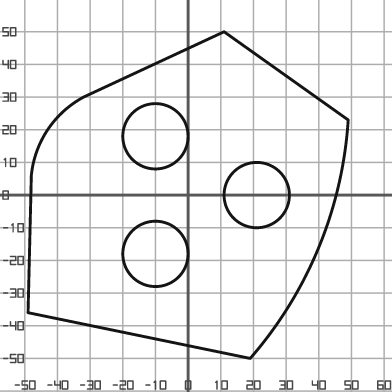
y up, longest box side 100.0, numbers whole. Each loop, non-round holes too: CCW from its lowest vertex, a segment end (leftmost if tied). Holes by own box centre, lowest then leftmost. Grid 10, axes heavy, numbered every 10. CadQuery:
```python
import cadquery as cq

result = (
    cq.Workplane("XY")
    .moveTo(19.0, -50.0)
    .threePointArc((40.0, -16.0), (49.0, 23.0))
    .lineTo(11.0, 50.0)
    .lineTo(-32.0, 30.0)
    .threePointArc((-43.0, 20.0), (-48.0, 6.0))
    .lineTo(-49.0, -36.0)
    .close()
    .moveTo(-10.0, -18.0)
    .circle(10.0)
    .moveTo(21.0, 0.0)
    .circle(10.0)
    .moveTo(-10.0, 18.0)
    .circle(10.0)
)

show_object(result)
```